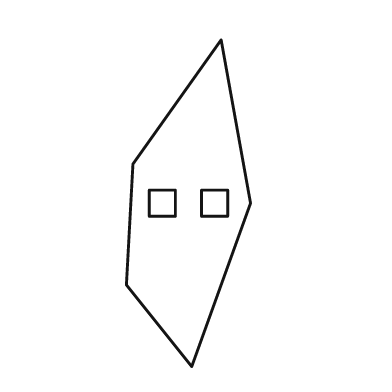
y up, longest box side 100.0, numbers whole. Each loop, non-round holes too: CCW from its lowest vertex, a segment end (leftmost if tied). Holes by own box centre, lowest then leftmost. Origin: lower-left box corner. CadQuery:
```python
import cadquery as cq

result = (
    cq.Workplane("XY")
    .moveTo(20.0, 0.0)
    .lineTo(38.0, 50.0)
    .lineTo(29.0, 100.0)
    .lineTo(2.0, 62.0)
    .lineTo(0.0, 25.0)
    .close()
    .moveTo(7.0, 46.0)
    .lineTo(15.0, 46.0)
    .lineTo(15.0, 54.0)
    .lineTo(7.0, 54.0)
    .close()
    .moveTo(23.0, 46.0)
    .lineTo(31.0, 46.0)
    .lineTo(31.0, 54.0)
    .lineTo(23.0, 54.0)
    .close()
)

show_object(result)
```